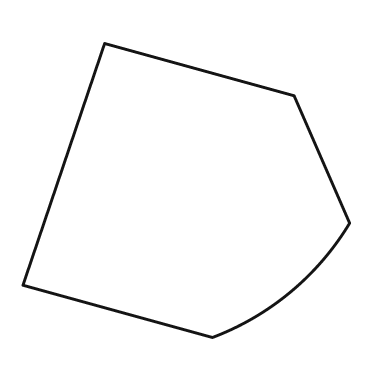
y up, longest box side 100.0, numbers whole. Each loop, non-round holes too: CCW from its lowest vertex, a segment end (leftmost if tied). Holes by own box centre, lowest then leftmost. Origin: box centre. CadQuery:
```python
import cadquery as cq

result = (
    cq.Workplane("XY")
    .moveTo(8.0, -45.0)
    .threePointArc((32.0, -31.0), (50.0, -10.0))
    .lineTo(33.0, 29.0)
    .lineTo(-25.0, 45.0)
    .lineTo(-50.0, -29.0)
    .close()
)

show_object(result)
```